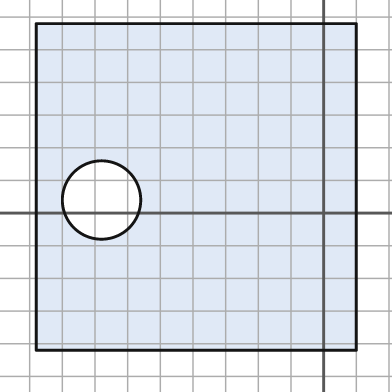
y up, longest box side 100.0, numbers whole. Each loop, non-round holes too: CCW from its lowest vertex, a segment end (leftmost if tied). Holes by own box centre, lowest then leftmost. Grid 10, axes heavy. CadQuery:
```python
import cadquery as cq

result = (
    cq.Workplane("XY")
    .moveTo(-88.0, -42.0)
    .lineTo(10.0, -42.0)
    .lineTo(10.0, 58.0)
    .lineTo(-88.0, 58.0)
    .close()
    .moveTo(-68.0, 4.0)
    .circle(12.0)
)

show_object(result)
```